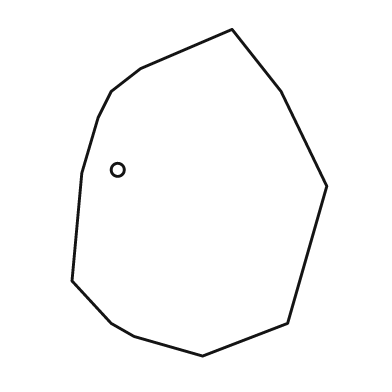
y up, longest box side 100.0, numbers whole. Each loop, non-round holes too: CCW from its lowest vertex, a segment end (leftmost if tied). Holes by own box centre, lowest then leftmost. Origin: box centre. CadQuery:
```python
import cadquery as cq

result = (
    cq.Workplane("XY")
    .moveTo(1.0, -50.0)
    .lineTo(27.0, -40.0)
    .lineTo(39.0, 2.0)
    .lineTo(25.0, 31.0)
    .lineTo(10.0, 50.0)
    .lineTo(-18.0, 38.0)
    .lineTo(-27.0, 31.0)
    .lineTo(-31.0, 23.0)
    .lineTo(-36.0, 6.0)
    .lineTo(-39.0, -27.0)
    .lineTo(-27.0, -40.0)
    .lineTo(-20.0, -44.0)
    .close()
    .moveTo(-25.0, 7.0)
    .circle(2.0)
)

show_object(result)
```